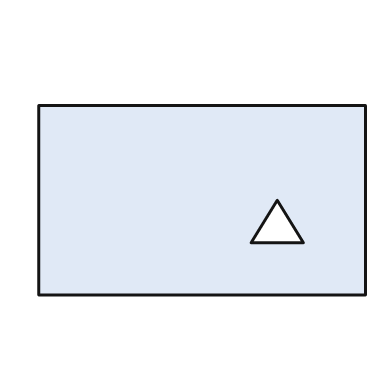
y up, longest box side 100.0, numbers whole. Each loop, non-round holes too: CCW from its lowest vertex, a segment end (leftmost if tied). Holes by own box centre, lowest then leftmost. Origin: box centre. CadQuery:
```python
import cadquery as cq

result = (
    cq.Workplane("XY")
    .moveTo(-50.0, -29.0)
    .lineTo(50.0, -29.0)
    .lineTo(50.0, 29.0)
    .lineTo(-50.0, 29.0)
    .close()
    .moveTo(15.0, -13.0)
    .lineTo(31.0, -13.0)
    .lineTo(23.0, 0.0)
    .close()
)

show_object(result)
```